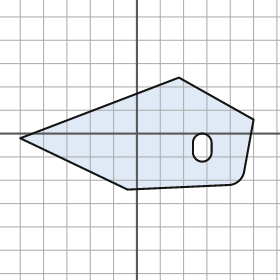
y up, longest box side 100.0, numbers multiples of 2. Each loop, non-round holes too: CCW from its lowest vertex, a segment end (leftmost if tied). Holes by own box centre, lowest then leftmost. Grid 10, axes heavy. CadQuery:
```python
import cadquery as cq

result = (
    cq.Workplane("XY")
    .moveTo(-4.0, -24.0)
    .lineTo(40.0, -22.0)
    .threePointArc((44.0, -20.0), (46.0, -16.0))
    .lineTo(50.0, 6.0)
    .lineTo(18.0, 24.0)
    .lineTo(-50.0, -2.0)
    .close()
    .moveTo(24.0, -8.0)
    .threePointArc((28.0, -12.0), (32.0, -8.0))
    .lineTo(32.0, -4.0)
    .threePointArc((28.0, 0.0), (24.0, -4.0))
    .close()
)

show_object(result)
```